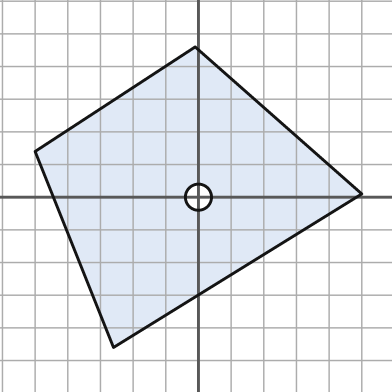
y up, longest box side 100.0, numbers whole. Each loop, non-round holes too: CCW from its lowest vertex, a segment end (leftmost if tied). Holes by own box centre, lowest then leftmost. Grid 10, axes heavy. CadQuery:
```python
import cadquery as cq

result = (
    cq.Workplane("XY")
    .moveTo(-26.0, -46.0)
    .lineTo(50.0, 1.0)
    .lineTo(-1.0, 46.0)
    .lineTo(-50.0, 14.0)
    .close()
    .moveTo(0.0, 0.0)
    .circle(4.0)
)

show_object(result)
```